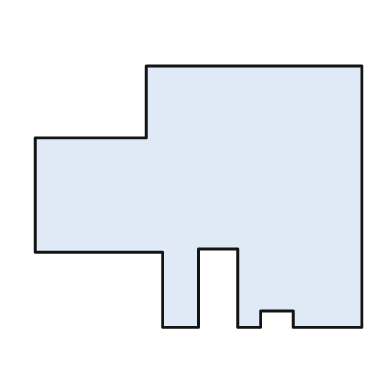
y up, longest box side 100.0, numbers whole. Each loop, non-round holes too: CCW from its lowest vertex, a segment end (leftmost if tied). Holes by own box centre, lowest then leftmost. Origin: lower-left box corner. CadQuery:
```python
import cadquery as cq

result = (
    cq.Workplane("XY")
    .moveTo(39.0, 0.0)
    .lineTo(50.0, 0.0)
    .lineTo(50.0, 24.0)
    .lineTo(62.0, 24.0)
    .lineTo(62.0, 0.0)
    .lineTo(69.0, 0.0)
    .lineTo(69.0, 5.0)
    .lineTo(79.0, 5.0)
    .lineTo(79.0, 0.0)
    .lineTo(100.0, 0.0)
    .lineTo(100.0, 80.0)
    .lineTo(34.0, 80.0)
    .lineTo(34.0, 58.0)
    .lineTo(0.0, 58.0)
    .lineTo(0.0, 23.0)
    .lineTo(39.0, 23.0)
    .close()
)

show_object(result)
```